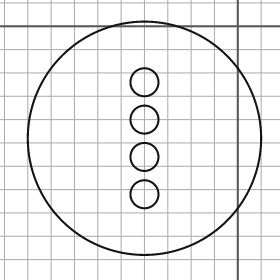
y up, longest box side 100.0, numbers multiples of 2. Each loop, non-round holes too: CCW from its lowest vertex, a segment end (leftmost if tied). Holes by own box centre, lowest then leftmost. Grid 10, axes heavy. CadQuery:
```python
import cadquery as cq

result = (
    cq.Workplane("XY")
    .moveTo(-40.0, -48.0)
    .circle(50.0)
    .moveTo(-40.0, -72.0)
    .circle(6.0)
    .moveTo(-40.0, -56.0)
    .circle(6.0)
    .moveTo(-40.0, -40.0)
    .circle(6.0)
    .moveTo(-40.0, -24.0)
    .circle(6.0)
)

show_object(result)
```